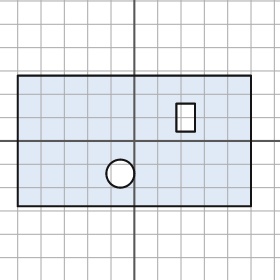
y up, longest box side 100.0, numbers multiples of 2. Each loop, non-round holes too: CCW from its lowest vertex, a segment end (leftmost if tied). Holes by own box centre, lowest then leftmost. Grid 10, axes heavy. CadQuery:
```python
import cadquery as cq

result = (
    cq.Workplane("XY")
    .moveTo(-50.0, -28.0)
    .lineTo(50.0, -28.0)
    .lineTo(50.0, 28.0)
    .lineTo(-50.0, 28.0)
    .close()
    .moveTo(-6.0, -14.0)
    .circle(6.0)
    .moveTo(18.0, 4.0)
    .lineTo(26.0, 4.0)
    .lineTo(26.0, 16.0)
    .lineTo(18.0, 16.0)
    .close()
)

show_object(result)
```